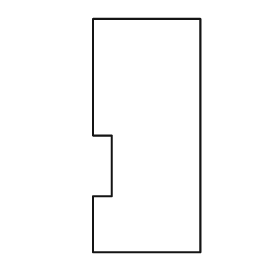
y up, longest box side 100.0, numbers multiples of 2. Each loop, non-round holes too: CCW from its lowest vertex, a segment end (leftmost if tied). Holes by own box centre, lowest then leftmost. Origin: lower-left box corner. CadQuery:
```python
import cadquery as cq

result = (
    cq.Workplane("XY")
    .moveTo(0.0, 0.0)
    .lineTo(46.0, 0.0)
    .lineTo(46.0, 100.0)
    .lineTo(0.0, 100.0)
    .lineTo(0.0, 50.0)
    .lineTo(8.0, 50.0)
    .lineTo(8.0, 24.0)
    .lineTo(0.0, 24.0)
    .close()
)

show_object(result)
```